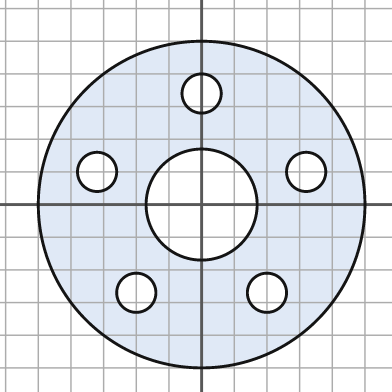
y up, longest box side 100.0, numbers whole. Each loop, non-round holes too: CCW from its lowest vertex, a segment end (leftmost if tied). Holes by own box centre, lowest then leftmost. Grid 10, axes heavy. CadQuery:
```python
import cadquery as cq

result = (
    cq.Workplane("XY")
    .moveTo(0.0, 0.0)
    .circle(50.0)
    .moveTo(-20.0, -27.0)
    .circle(6.0)
    .moveTo(20.0, -27.0)
    .circle(6.0)
    .moveTo(0.0, 0.0)
    .circle(17.0)
    .moveTo(-32.0, 10.0)
    .circle(6.0)
    .moveTo(32.0, 10.0)
    .circle(6.0)
    .moveTo(0.0, 34.0)
    .circle(6.0)
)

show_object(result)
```